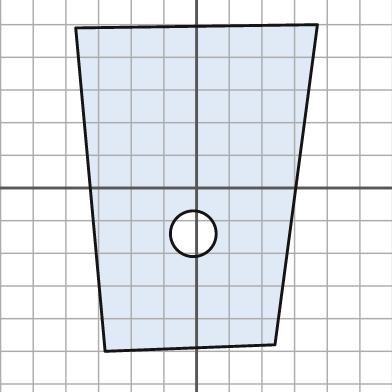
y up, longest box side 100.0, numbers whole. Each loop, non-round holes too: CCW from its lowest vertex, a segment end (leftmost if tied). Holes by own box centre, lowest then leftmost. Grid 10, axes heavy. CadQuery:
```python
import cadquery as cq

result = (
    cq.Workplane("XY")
    .moveTo(-28.0, -50.0)
    .lineTo(24.0, -48.0)
    .lineTo(37.0, 50.0)
    .lineTo(-37.0, 49.0)
    .close()
    .moveTo(-1.0, -14.0)
    .circle(7.0)
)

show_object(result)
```